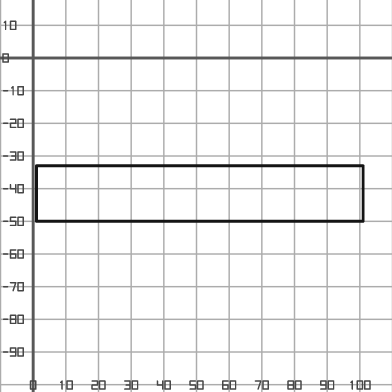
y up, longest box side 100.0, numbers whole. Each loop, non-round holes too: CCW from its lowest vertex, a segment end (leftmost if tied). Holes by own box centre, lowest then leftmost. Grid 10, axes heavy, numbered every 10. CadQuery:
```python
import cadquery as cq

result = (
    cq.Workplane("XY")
    .moveTo(1.0, -50.0)
    .lineTo(101.0, -50.0)
    .lineTo(101.0, -33.0)
    .lineTo(1.0, -33.0)
    .close()
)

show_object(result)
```